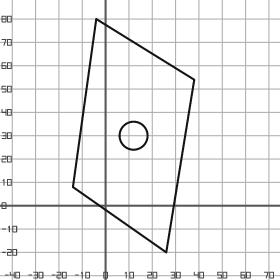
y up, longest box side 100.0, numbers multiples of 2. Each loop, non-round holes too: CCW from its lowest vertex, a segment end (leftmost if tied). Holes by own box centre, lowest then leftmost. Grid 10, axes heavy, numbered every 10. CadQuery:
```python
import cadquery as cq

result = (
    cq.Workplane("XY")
    .moveTo(26.0, -20.0)
    .lineTo(38.0, 54.0)
    .lineTo(-4.0, 80.0)
    .lineTo(-14.0, 8.0)
    .close()
    .moveTo(12.0, 30.0)
    .circle(6.0)
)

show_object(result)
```